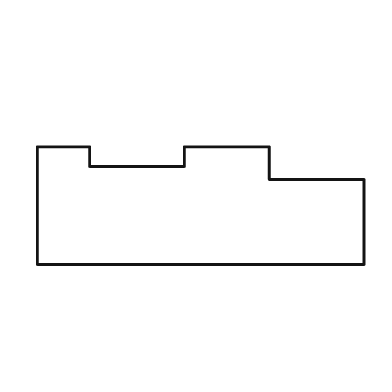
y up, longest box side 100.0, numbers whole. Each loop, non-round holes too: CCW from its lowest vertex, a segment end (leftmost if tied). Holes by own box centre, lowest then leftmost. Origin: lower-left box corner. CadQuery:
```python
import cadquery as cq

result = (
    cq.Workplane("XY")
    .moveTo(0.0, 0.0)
    .lineTo(100.0, 0.0)
    .lineTo(100.0, 26.0)
    .lineTo(71.0, 26.0)
    .lineTo(71.0, 36.0)
    .lineTo(45.0, 36.0)
    .lineTo(45.0, 30.0)
    .lineTo(16.0, 30.0)
    .lineTo(16.0, 36.0)
    .lineTo(0.0, 36.0)
    .close()
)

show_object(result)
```